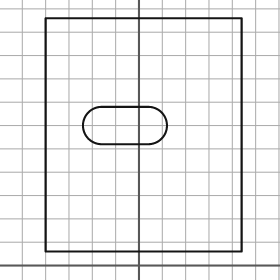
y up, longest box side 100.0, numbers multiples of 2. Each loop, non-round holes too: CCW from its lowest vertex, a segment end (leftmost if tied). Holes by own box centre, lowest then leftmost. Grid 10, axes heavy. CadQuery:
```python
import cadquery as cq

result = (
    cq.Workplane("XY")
    .moveTo(-40.0, 6.0)
    .lineTo(44.0, 6.0)
    .lineTo(44.0, 106.0)
    .lineTo(-40.0, 106.0)
    .close()
    .moveTo(-16.0, 52.0)
    .lineTo(4.0, 52.0)
    .threePointArc((12.0, 60.0), (4.0, 68.0))
    .lineTo(-16.0, 68.0)
    .threePointArc((-24.0, 60.0), (-16.0, 52.0))
    .close()
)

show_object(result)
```